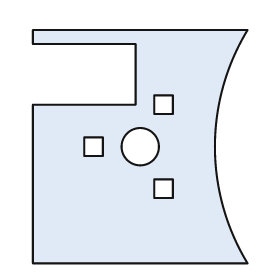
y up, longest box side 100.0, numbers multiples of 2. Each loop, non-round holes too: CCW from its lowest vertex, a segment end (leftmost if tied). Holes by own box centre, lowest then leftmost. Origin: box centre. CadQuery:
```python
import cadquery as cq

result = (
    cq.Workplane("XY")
    .moveTo(-46.0, -50.0)
    .lineTo(46.0, -50.0)
    .threePointArc((32.0, 0.0), (46.0, 50.0))
    .lineTo(-46.0, 50.0)
    .lineTo(-46.0, 44.0)
    .lineTo(-2.0, 44.0)
    .lineTo(-2.0, 18.0)
    .lineTo(-46.0, 18.0)
    .close()
    .moveTo(6.0, -22.0)
    .lineTo(14.0, -22.0)
    .lineTo(14.0, -14.0)
    .lineTo(6.0, -14.0)
    .close()
    .moveTo(-24.0, -4.0)
    .lineTo(-16.0, -4.0)
    .lineTo(-16.0, 4.0)
    .lineTo(-24.0, 4.0)
    .close()
    .moveTo(0.0, 0.0)
    .circle(8.0)
    .moveTo(6.0, 14.0)
    .lineTo(14.0, 14.0)
    .lineTo(14.0, 22.0)
    .lineTo(6.0, 22.0)
    .close()
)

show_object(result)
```